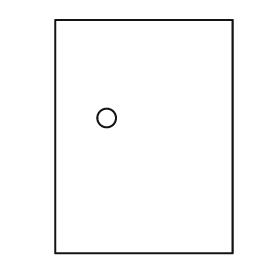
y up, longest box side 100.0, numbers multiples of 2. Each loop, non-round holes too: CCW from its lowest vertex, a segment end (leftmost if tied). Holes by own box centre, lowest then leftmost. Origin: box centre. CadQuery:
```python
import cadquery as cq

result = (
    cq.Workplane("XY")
    .moveTo(-38.0, -50.0)
    .lineTo(38.0, -50.0)
    .lineTo(38.0, 50.0)
    .lineTo(-38.0, 50.0)
    .close()
    .moveTo(-16.0, 8.0)
    .circle(4.0)
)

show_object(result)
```